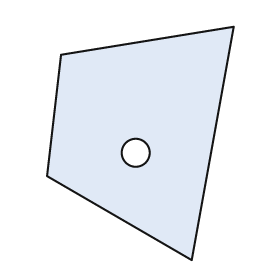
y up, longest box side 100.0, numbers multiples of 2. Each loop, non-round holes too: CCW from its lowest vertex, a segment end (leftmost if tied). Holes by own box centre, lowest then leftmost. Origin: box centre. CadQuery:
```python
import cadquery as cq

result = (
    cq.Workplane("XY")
    .moveTo(22.0, -50.0)
    .lineTo(40.0, 50.0)
    .lineTo(-34.0, 38.0)
    .lineTo(-40.0, -14.0)
    .close()
    .moveTo(-2.0, -4.0)
    .circle(6.0)
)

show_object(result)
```